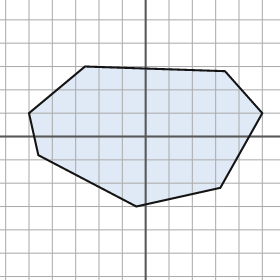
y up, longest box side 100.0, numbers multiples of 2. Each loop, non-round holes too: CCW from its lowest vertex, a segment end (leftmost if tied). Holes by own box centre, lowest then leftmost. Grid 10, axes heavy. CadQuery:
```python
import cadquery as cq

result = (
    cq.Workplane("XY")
    .moveTo(-4.0, -30.0)
    .lineTo(32.0, -22.0)
    .lineTo(50.0, 10.0)
    .lineTo(34.0, 28.0)
    .lineTo(-26.0, 30.0)
    .lineTo(-50.0, 10.0)
    .lineTo(-46.0, -8.0)
    .close()
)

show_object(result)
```